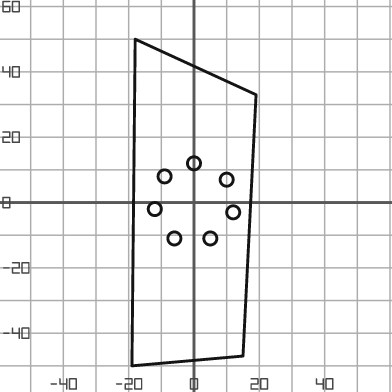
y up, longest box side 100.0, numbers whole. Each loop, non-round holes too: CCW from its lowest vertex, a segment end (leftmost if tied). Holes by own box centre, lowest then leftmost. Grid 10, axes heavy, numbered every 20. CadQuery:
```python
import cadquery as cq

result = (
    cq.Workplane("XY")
    .moveTo(-19.0, -50.0)
    .lineTo(15.0, -47.0)
    .lineTo(19.0, 33.0)
    .lineTo(-18.0, 50.0)
    .close()
    .moveTo(-6.0, -11.0)
    .circle(2.0)
    .moveTo(5.0, -11.0)
    .circle(2.0)
    .moveTo(12.0, -3.0)
    .circle(2.0)
    .moveTo(-12.0, -2.0)
    .circle(2.0)
    .moveTo(10.0, 7.0)
    .circle(2.0)
    .moveTo(-9.0, 8.0)
    .circle(2.0)
    .moveTo(0.0, 12.0)
    .circle(2.0)
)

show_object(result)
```